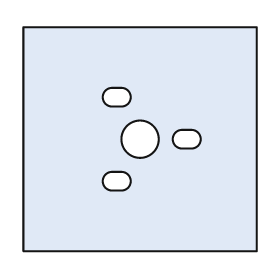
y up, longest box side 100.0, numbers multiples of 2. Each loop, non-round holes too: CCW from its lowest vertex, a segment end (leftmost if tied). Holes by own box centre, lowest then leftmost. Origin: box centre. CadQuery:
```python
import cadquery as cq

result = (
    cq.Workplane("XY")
    .moveTo(-50.0, -48.0)
    .lineTo(50.0, -48.0)
    .lineTo(50.0, 48.0)
    .lineTo(-50.0, 48.0)
    .close()
    .moveTo(-12.0, -22.0)
    .lineTo(-8.0, -22.0)
    .threePointArc((-4.0, -18.0), (-8.0, -14.0))
    .lineTo(-12.0, -14.0)
    .threePointArc((-16.0, -18.0), (-12.0, -22.0))
    .close()
    .moveTo(0.0, 0.0)
    .circle(8.0)
    .moveTo(18.0, -4.0)
    .lineTo(22.0, -4.0)
    .threePointArc((26.0, 0.0), (22.0, 4.0))
    .lineTo(18.0, 4.0)
    .threePointArc((14.0, 0.0), (18.0, -4.0))
    .close()
    .moveTo(-12.0, 14.0)
    .lineTo(-8.0, 14.0)
    .threePointArc((-4.0, 18.0), (-8.0, 22.0))
    .lineTo(-12.0, 22.0)
    .threePointArc((-16.0, 18.0), (-12.0, 14.0))
    .close()
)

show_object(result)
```